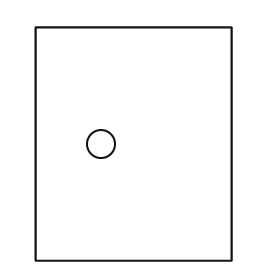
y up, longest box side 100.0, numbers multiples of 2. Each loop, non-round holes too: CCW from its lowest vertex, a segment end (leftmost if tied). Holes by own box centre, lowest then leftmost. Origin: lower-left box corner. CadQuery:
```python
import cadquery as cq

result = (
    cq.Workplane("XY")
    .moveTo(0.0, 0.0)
    .lineTo(84.0, 0.0)
    .lineTo(84.0, 100.0)
    .lineTo(0.0, 100.0)
    .close()
    .moveTo(28.0, 50.0)
    .circle(6.0)
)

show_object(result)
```